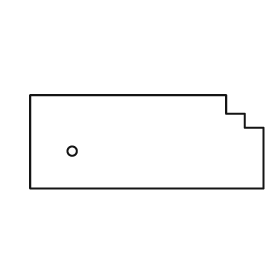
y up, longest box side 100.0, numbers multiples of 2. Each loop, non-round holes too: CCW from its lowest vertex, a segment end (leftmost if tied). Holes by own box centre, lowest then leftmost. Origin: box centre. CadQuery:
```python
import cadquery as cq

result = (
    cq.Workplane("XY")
    .moveTo(-50.0, -20.0)
    .lineTo(50.0, -20.0)
    .lineTo(50.0, 6.0)
    .lineTo(42.0, 6.0)
    .lineTo(42.0, 12.0)
    .lineTo(34.0, 12.0)
    .lineTo(34.0, 20.0)
    .lineTo(-50.0, 20.0)
    .close()
    .moveTo(-32.0, -4.0)
    .circle(2.0)
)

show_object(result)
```